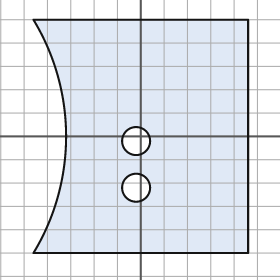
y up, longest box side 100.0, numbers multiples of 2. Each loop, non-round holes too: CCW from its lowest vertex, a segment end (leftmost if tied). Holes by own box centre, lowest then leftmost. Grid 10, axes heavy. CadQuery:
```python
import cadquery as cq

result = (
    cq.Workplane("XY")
    .moveTo(-46.0, -50.0)
    .lineTo(46.0, -50.0)
    .lineTo(46.0, 50.0)
    .lineTo(-46.0, 50.0)
    .threePointArc((-32.0, 0.0), (-46.0, -50.0))
    .close()
    .moveTo(-2.0, -22.0)
    .circle(6.0)
    .moveTo(-2.0, -2.0)
    .circle(6.0)
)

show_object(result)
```